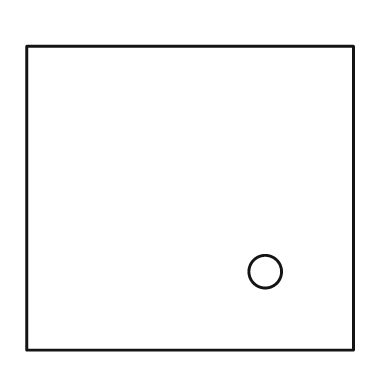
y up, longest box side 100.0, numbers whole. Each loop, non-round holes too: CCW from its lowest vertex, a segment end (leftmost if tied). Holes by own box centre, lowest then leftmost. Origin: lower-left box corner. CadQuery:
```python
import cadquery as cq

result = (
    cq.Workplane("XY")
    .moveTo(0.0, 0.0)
    .lineTo(100.0, 0.0)
    .lineTo(100.0, 93.0)
    .lineTo(0.0, 93.0)
    .close()
    .moveTo(73.0, 24.0)
    .circle(5.0)
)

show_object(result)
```